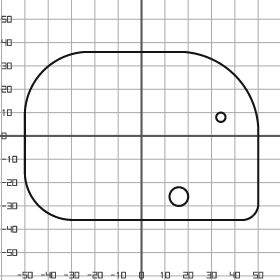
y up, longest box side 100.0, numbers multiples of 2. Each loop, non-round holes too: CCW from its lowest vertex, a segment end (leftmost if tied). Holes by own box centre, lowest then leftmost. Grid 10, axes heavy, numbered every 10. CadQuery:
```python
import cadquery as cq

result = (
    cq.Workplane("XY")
    .moveTo(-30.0, -36.0)
    .lineTo(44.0, -36.0)
    .threePointArc((48.0, -34.0), (50.0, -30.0))
    .lineTo(50.0, 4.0)
    .threePointArc((40.0, 26.0), (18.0, 36.0))
    .lineTo(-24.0, 36.0)
    .threePointArc((-42.0, 28.0), (-50.0, 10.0))
    .lineTo(-50.0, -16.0)
    .threePointArc((-44.0, -30.0), (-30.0, -36.0))
    .close()
    .moveTo(16.0, -26.0)
    .circle(4.0)
    .moveTo(34.0, 8.0)
    .circle(2.0)
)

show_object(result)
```